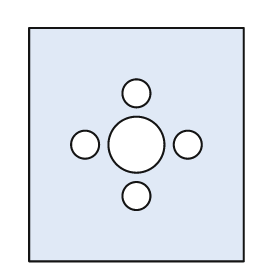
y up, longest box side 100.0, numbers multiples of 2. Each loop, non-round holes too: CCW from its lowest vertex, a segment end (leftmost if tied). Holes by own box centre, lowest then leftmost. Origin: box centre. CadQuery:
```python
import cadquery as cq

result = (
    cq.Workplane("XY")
    .moveTo(-46.0, -50.0)
    .lineTo(46.0, -50.0)
    .lineTo(46.0, 50.0)
    .lineTo(-46.0, 50.0)
    .close()
    .moveTo(0.0, -22.0)
    .circle(6.0)
    .moveTo(-22.0, 0.0)
    .circle(6.0)
    .moveTo(0.0, 0.0)
    .circle(12.0)
    .moveTo(22.0, 0.0)
    .circle(6.0)
    .moveTo(0.0, 22.0)
    .circle(6.0)
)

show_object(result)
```